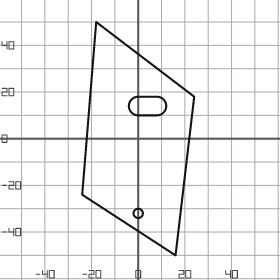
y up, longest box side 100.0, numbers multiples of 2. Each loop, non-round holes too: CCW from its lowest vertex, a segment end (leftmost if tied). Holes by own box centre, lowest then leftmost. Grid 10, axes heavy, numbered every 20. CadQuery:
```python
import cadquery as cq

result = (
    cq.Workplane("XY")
    .moveTo(16.0, -50.0)
    .lineTo(24.0, 18.0)
    .lineTo(-18.0, 50.0)
    .lineTo(-24.0, -24.0)
    .close()
    .moveTo(0.0, -32.0)
    .circle(2.0)
    .moveTo(0.0, 10.0)
    .lineTo(8.0, 10.0)
    .threePointArc((12.0, 14.0), (8.0, 18.0))
    .lineTo(0.0, 18.0)
    .threePointArc((-4.0, 14.0), (0.0, 10.0))
    .close()
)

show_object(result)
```